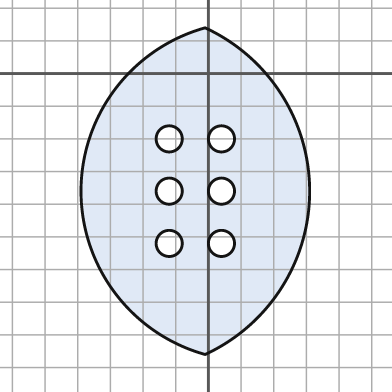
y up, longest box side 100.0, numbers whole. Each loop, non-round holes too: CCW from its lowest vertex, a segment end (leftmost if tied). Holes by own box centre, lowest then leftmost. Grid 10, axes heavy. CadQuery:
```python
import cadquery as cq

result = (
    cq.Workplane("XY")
    .moveTo(-1.0, -86.0)
    .threePointArc((31.0, -36.0), (-1.0, 14.0))
    .threePointArc((-39.0, -36.0), (-1.0, -86.0))
    .close()
    .moveTo(-12.0, -52.0)
    .circle(4.0)
    .moveTo(4.0, -52.0)
    .circle(4.0)
    .moveTo(-12.0, -36.0)
    .circle(4.0)
    .moveTo(4.0, -36.0)
    .circle(4.0)
    .moveTo(-12.0, -20.0)
    .circle(4.0)
    .moveTo(4.0, -20.0)
    .circle(4.0)
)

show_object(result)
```